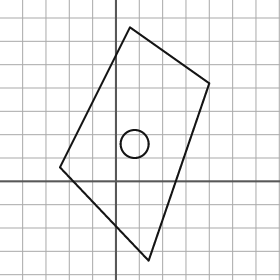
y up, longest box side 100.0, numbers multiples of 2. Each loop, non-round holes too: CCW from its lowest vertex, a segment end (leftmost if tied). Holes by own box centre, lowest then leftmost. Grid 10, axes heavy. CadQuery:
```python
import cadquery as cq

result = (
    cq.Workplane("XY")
    .moveTo(14.0, -34.0)
    .lineTo(40.0, 42.0)
    .lineTo(6.0, 66.0)
    .lineTo(-24.0, 6.0)
    .close()
    .moveTo(8.0, 16.0)
    .circle(6.0)
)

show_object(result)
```